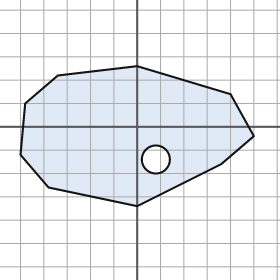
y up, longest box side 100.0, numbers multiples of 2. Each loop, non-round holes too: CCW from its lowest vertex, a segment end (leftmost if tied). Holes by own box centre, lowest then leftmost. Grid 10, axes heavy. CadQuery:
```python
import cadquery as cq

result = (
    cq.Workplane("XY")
    .moveTo(0.0, -34.0)
    .lineTo(36.0, -16.0)
    .lineTo(50.0, -4.0)
    .lineTo(40.0, 14.0)
    .lineTo(0.0, 26.0)
    .lineTo(-34.0, 22.0)
    .lineTo(-48.0, 10.0)
    .lineTo(-50.0, -12.0)
    .lineTo(-38.0, -26.0)
    .close()
    .moveTo(8.0, -14.0)
    .circle(6.0)
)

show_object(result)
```